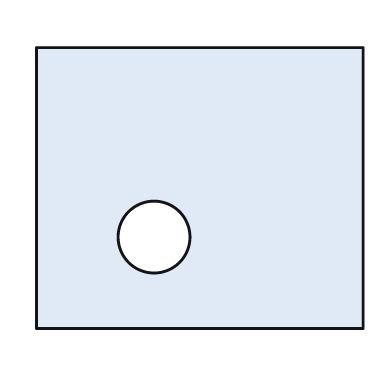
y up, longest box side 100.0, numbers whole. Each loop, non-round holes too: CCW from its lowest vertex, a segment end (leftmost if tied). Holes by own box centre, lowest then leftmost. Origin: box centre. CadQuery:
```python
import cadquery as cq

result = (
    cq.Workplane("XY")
    .moveTo(-50.0, -43.0)
    .lineTo(50.0, -43.0)
    .lineTo(50.0, 43.0)
    .lineTo(-50.0, 43.0)
    .close()
    .moveTo(-14.0, -15.0)
    .circle(11.0)
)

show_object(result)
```